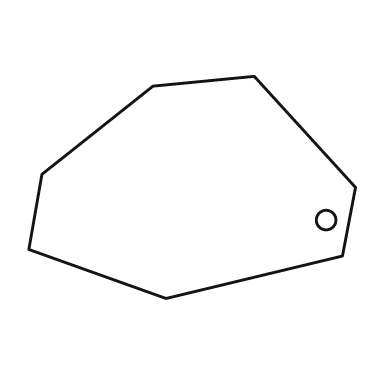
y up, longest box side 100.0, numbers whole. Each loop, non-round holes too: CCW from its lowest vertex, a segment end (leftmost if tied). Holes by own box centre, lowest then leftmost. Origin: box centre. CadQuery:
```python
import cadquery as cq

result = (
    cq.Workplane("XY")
    .moveTo(-8.0, -34.0)
    .lineTo(46.0, -21.0)
    .lineTo(50.0, 0.0)
    .lineTo(19.0, 34.0)
    .lineTo(-12.0, 31.0)
    .lineTo(-46.0, 4.0)
    .lineTo(-50.0, -19.0)
    .close()
    .moveTo(41.0, -10.0)
    .circle(3.0)
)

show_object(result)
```